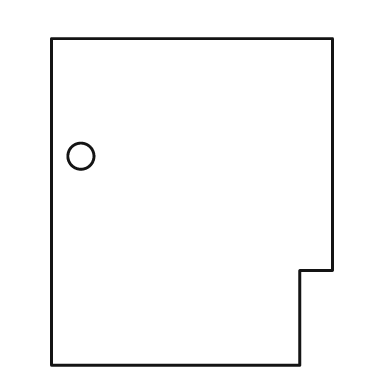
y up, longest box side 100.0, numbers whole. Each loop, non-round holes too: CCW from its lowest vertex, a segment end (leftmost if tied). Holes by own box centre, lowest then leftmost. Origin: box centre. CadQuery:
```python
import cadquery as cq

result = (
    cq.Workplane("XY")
    .moveTo(-43.0, -50.0)
    .lineTo(33.0, -50.0)
    .lineTo(33.0, -21.0)
    .lineTo(43.0, -21.0)
    .lineTo(43.0, 50.0)
    .lineTo(-43.0, 50.0)
    .close()
    .moveTo(-34.0, 14.0)
    .circle(4.0)
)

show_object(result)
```